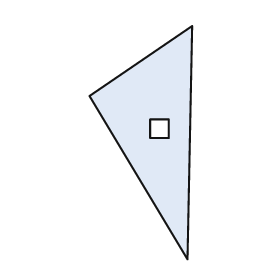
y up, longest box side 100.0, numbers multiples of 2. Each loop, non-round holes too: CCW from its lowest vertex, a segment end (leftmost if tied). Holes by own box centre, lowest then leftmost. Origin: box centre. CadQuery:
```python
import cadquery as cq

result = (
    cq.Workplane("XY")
    .moveTo(20.0, -50.0)
    .lineTo(22.0, 50.0)
    .lineTo(-22.0, 20.0)
    .close()
    .moveTo(4.0, 2.0)
    .lineTo(12.0, 2.0)
    .lineTo(12.0, 10.0)
    .lineTo(4.0, 10.0)
    .close()
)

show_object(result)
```